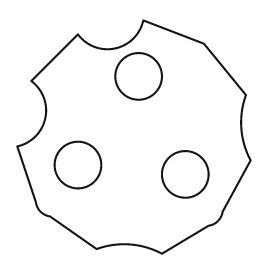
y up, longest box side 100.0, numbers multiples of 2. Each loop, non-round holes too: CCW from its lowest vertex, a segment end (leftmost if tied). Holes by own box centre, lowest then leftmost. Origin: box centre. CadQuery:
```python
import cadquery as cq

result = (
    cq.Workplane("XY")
    .moveTo(12.0, -50.0)
    .lineTo(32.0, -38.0)
    .threePointArc((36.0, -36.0), (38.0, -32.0))
    .lineTo(50.0, -10.0)
    .threePointArc((46.0, 4.0), (48.0, 18.0))
    .lineTo(30.0, 40.0)
    .lineTo(4.0, 50.0)
    .threePointArc((-8.0, 38.0), (-24.0, 44.0))
    .lineTo(-44.0, 24.0)
    .threePointArc((-38.0, 8.0), (-50.0, -4.0))
    .lineTo(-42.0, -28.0)
    .threePointArc((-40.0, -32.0), (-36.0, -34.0))
    .lineTo(-16.0, -48.0)
    .threePointArc((-2.0, -46.0), (12.0, -50.0))
    .close()
    .moveTo(22.0, -16.0)
    .circle(10.0)
    .moveTo(-24.0, -12.0)
    .circle(10.0)
    .moveTo(2.0, 26.0)
    .circle(10.0)
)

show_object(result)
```